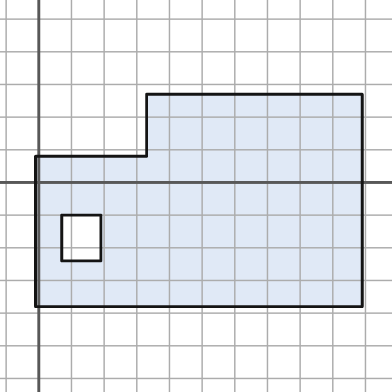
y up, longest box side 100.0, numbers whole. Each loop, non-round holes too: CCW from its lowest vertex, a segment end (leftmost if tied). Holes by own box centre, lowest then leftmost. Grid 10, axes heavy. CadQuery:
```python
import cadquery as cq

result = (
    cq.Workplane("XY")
    .moveTo(-1.0, -38.0)
    .lineTo(99.0, -38.0)
    .lineTo(99.0, 27.0)
    .lineTo(33.0, 27.0)
    .lineTo(33.0, 8.0)
    .lineTo(-1.0, 8.0)
    .close()
    .moveTo(7.0, -24.0)
    .lineTo(19.0, -24.0)
    .lineTo(19.0, -10.0)
    .lineTo(7.0, -10.0)
    .close()
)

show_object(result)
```